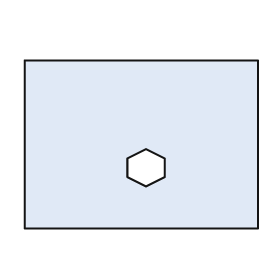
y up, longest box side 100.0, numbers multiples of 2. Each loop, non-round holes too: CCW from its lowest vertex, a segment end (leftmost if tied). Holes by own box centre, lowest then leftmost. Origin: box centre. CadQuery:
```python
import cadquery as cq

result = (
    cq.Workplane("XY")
    .moveTo(-50.0, -36.0)
    .lineTo(50.0, -36.0)
    .lineTo(50.0, 36.0)
    .lineTo(-50.0, 36.0)
    .close()
    .moveTo(2.0, -18.0)
    .lineTo(10.0, -14.0)
    .lineTo(10.0, -6.0)
    .lineTo(2.0, -2.0)
    .lineTo(-6.0, -6.0)
    .lineTo(-6.0, -14.0)
    .close()
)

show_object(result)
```